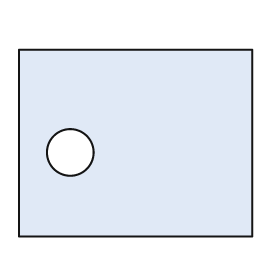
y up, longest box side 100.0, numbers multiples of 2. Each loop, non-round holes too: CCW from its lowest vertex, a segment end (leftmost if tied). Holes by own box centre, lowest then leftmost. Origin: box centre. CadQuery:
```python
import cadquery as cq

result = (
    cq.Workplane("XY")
    .moveTo(-50.0, -40.0)
    .lineTo(50.0, -40.0)
    .lineTo(50.0, 40.0)
    .lineTo(-50.0, 40.0)
    .close()
    .moveTo(-28.0, -4.0)
    .circle(10.0)
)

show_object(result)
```